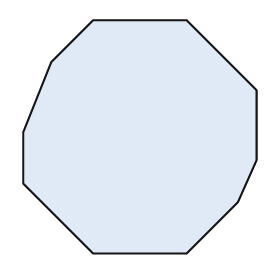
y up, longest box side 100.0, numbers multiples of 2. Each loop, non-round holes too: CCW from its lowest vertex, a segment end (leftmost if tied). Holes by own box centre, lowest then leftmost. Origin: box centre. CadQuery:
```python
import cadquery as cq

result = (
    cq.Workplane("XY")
    .moveTo(-20.0, -50.0)
    .lineTo(20.0, -50.0)
    .lineTo(42.0, -28.0)
    .lineTo(50.0, -10.0)
    .lineTo(50.0, 20.0)
    .lineTo(20.0, 50.0)
    .lineTo(-20.0, 50.0)
    .lineTo(-38.0, 32.0)
    .lineTo(-50.0, 2.0)
    .lineTo(-50.0, -20.0)
    .close()
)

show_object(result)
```